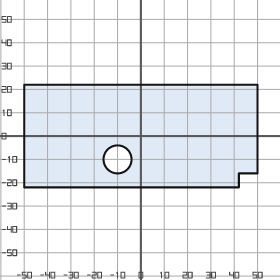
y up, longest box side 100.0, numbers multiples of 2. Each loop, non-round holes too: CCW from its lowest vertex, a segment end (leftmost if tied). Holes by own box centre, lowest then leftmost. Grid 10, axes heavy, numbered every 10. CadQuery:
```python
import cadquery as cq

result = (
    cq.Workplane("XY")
    .moveTo(-50.0, -22.0)
    .lineTo(42.0, -22.0)
    .lineTo(42.0, -16.0)
    .lineTo(50.0, -16.0)
    .lineTo(50.0, 22.0)
    .lineTo(-50.0, 22.0)
    .close()
    .moveTo(-10.0, -10.0)
    .circle(6.0)
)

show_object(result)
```